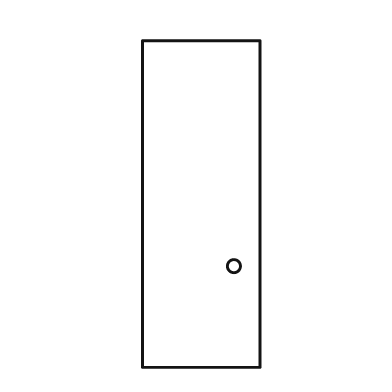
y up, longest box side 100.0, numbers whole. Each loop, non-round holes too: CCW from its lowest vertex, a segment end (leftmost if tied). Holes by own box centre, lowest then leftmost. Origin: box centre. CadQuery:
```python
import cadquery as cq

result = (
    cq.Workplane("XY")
    .moveTo(-18.0, -50.0)
    .lineTo(18.0, -50.0)
    .lineTo(18.0, 50.0)
    .lineTo(-18.0, 50.0)
    .close()
    .moveTo(10.0, -19.0)
    .circle(2.0)
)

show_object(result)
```